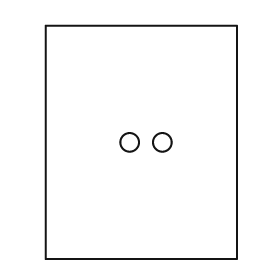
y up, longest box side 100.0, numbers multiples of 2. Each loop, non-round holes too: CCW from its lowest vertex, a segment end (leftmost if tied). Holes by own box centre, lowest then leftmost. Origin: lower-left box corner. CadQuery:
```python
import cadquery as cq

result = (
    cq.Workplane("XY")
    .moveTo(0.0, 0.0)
    .lineTo(82.0, 0.0)
    .lineTo(82.0, 100.0)
    .lineTo(0.0, 100.0)
    .close()
    .moveTo(36.0, 50.0)
    .circle(4.0)
    .moveTo(50.0, 50.0)
    .circle(4.0)
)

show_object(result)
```